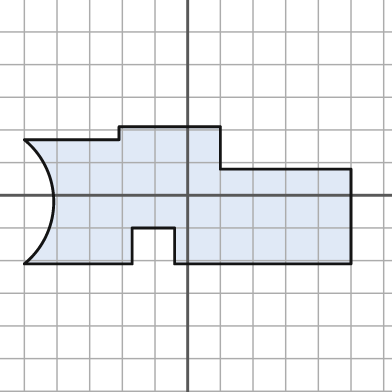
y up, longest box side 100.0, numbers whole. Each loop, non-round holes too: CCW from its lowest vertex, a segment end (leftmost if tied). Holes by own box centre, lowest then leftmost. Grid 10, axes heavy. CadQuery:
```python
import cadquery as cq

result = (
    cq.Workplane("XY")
    .moveTo(-50.0, -21.0)
    .lineTo(-17.0, -21.0)
    .lineTo(-17.0, -10.0)
    .lineTo(-4.0, -10.0)
    .lineTo(-4.0, -21.0)
    .lineTo(50.0, -21.0)
    .lineTo(50.0, 8.0)
    .lineTo(10.0, 8.0)
    .lineTo(10.0, 21.0)
    .lineTo(-21.0, 21.0)
    .lineTo(-21.0, 17.0)
    .lineTo(-50.0, 17.0)
    .threePointArc((-41.0, -2.0), (-50.0, -21.0))
    .close()
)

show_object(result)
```